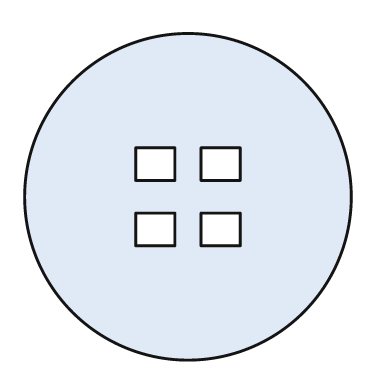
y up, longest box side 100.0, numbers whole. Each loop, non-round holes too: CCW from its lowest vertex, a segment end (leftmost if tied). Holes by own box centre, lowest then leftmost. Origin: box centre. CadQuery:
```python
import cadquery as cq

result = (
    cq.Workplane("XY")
    .moveTo(0.0, 0.0)
    .circle(50.0)
    .moveTo(-16.0, -15.0)
    .lineTo(-4.0, -15.0)
    .lineTo(-4.0, -5.0)
    .lineTo(-16.0, -5.0)
    .close()
    .moveTo(4.0, -15.0)
    .lineTo(16.0, -15.0)
    .lineTo(16.0, -5.0)
    .lineTo(4.0, -5.0)
    .close()
    .moveTo(-16.0, 5.0)
    .lineTo(-4.0, 5.0)
    .lineTo(-4.0, 15.0)
    .lineTo(-16.0, 15.0)
    .close()
    .moveTo(4.0, 5.0)
    .lineTo(16.0, 5.0)
    .lineTo(16.0, 15.0)
    .lineTo(4.0, 15.0)
    .close()
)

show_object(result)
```